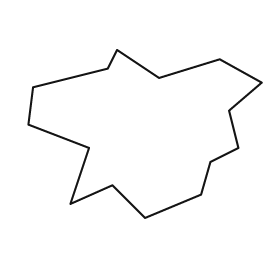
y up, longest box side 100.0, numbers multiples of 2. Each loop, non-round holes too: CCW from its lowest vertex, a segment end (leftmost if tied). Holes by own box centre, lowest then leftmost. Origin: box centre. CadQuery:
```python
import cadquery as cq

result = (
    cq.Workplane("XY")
    .moveTo(0.0, -36.0)
    .lineTo(24.0, -26.0)
    .lineTo(28.0, -12.0)
    .lineTo(40.0, -6.0)
    .lineTo(36.0, 10.0)
    .lineTo(50.0, 22.0)
    .lineTo(32.0, 32.0)
    .lineTo(6.0, 24.0)
    .lineTo(-12.0, 36.0)
    .lineTo(-16.0, 28.0)
    .lineTo(-48.0, 20.0)
    .lineTo(-50.0, 4.0)
    .lineTo(-24.0, -6.0)
    .lineTo(-32.0, -30.0)
    .lineTo(-14.0, -22.0)
    .close()
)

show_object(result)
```